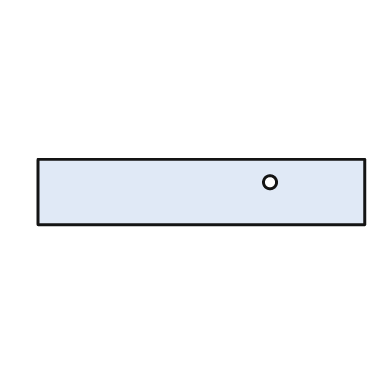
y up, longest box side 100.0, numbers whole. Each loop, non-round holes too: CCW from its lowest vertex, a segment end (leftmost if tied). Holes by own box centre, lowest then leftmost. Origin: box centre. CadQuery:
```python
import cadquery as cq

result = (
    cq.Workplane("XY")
    .moveTo(-50.0, -10.0)
    .lineTo(50.0, -10.0)
    .lineTo(50.0, 10.0)
    .lineTo(-50.0, 10.0)
    .close()
    .moveTo(21.0, 3.0)
    .circle(2.0)
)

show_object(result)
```